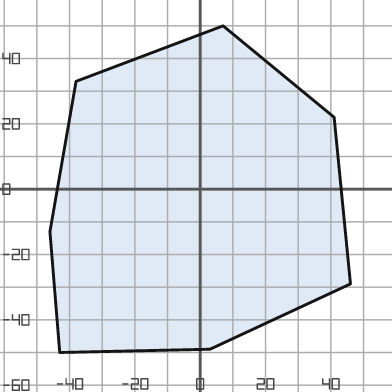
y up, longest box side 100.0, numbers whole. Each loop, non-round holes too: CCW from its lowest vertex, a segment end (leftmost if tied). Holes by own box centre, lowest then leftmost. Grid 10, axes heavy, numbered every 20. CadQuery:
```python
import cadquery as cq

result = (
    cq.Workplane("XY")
    .moveTo(-43.0, -50.0)
    .lineTo(3.0, -49.0)
    .lineTo(46.0, -29.0)
    .lineTo(41.0, 22.0)
    .lineTo(7.0, 50.0)
    .lineTo(-38.0, 33.0)
    .lineTo(-46.0, -13.0)
    .close()
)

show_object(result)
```